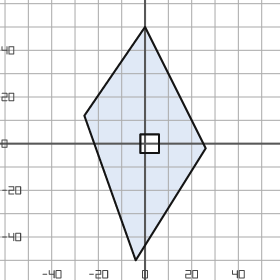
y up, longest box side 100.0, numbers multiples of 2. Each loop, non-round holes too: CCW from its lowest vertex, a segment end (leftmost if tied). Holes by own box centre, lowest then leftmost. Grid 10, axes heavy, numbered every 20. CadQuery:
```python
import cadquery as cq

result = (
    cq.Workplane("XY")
    .moveTo(-4.0, -50.0)
    .lineTo(26.0, -2.0)
    .lineTo(0.0, 50.0)
    .lineTo(-26.0, 12.0)
    .close()
    .moveTo(-2.0, -4.0)
    .lineTo(6.0, -4.0)
    .lineTo(6.0, 4.0)
    .lineTo(-2.0, 4.0)
    .close()
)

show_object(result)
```